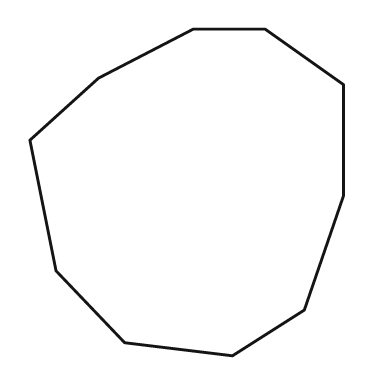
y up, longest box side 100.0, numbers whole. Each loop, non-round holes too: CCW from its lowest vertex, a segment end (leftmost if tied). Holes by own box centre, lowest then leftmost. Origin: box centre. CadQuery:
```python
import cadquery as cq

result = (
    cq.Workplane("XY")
    .moveTo(14.0, -50.0)
    .lineTo(36.0, -36.0)
    .lineTo(48.0, -1.0)
    .lineTo(48.0, 33.0)
    .lineTo(24.0, 50.0)
    .lineTo(2.0, 50.0)
    .lineTo(-27.0, 35.0)
    .lineTo(-48.0, 16.0)
    .lineTo(-40.0, -24.0)
    .lineTo(-19.0, -46.0)
    .close()
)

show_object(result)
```